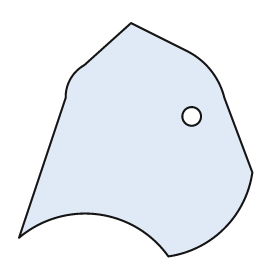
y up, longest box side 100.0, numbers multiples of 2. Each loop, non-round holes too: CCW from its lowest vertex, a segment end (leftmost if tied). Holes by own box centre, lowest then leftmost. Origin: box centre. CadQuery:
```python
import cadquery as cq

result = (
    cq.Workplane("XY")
    .moveTo(14.0, -50.0)
    .threePointArc((38.0, -38.0), (50.0, -14.0))
    .lineTo(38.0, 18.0)
    .threePointArc((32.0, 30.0), (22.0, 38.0))
    .lineTo(-2.0, 50.0)
    .lineTo(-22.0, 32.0)
    .threePointArc((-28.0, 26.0), (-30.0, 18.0))
    .lineTo(-50.0, -42.0)
    .threePointArc((-16.0, -32.0), (14.0, -50.0))
    .close()
    .moveTo(24.0, 10.0)
    .circle(4.0)
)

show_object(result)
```